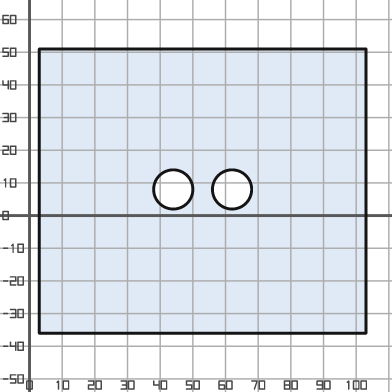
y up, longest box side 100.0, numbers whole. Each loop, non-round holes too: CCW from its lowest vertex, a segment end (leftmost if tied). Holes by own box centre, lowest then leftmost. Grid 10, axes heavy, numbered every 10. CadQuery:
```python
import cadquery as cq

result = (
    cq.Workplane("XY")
    .moveTo(3.0, -36.0)
    .lineTo(103.0, -36.0)
    .lineTo(103.0, 51.0)
    .lineTo(3.0, 51.0)
    .close()
    .moveTo(44.0, 8.0)
    .circle(6.0)
    .moveTo(62.0, 8.0)
    .circle(6.0)
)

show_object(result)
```